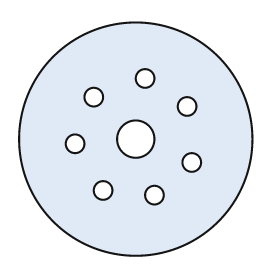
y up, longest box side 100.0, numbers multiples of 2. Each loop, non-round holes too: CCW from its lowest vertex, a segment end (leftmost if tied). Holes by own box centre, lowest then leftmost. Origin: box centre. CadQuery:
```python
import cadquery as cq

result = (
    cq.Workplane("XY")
    .moveTo(0.0, 0.0)
    .circle(50.0)
    .moveTo(8.0, -24.0)
    .circle(4.0)
    .moveTo(-14.0, -22.0)
    .circle(4.0)
    .moveTo(24.0, -10.0)
    .circle(4.0)
    .moveTo(-26.0, -2.0)
    .circle(4.0)
    .moveTo(0.0, 0.0)
    .circle(8.0)
    .moveTo(22.0, 14.0)
    .circle(4.0)
    .moveTo(-18.0, 18.0)
    .circle(4.0)
    .moveTo(4.0, 26.0)
    .circle(4.0)
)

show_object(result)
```